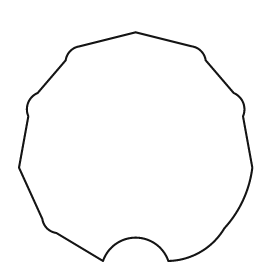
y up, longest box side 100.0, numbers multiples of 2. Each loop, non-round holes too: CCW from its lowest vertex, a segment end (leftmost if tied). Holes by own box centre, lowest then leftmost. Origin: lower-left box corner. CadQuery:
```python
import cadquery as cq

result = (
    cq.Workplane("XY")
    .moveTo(36.0, 0.0)
    .threePointArc((50.0, 10.0), (64.0, 0.0))
    .threePointArc((78.0, 4.0), (88.0, 14.0))
    .threePointArc((96.0, 26.0), (100.0, 40.0))
    .lineTo(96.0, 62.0)
    .threePointArc((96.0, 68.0), (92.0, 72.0))
    .lineTo(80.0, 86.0)
    .threePointArc((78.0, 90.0), (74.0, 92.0))
    .lineTo(50.0, 98.0)
    .lineTo(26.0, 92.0)
    .threePointArc((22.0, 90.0), (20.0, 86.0))
    .lineTo(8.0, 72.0)
    .threePointArc((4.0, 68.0), (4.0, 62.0))
    .lineTo(0.0, 40.0)
    .lineTo(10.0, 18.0)
    .threePointArc((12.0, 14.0), (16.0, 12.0))
    .close()
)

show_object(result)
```